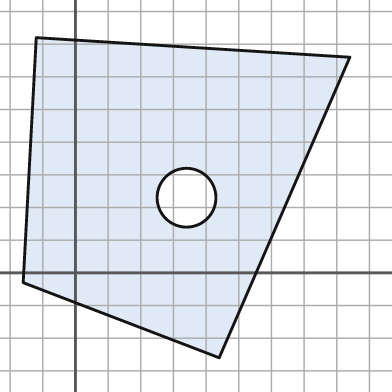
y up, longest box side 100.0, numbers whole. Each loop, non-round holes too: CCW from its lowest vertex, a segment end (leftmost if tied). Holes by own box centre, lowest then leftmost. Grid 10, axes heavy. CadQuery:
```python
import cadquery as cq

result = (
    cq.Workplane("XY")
    .moveTo(44.0, -26.0)
    .lineTo(84.0, 66.0)
    .lineTo(-12.0, 72.0)
    .lineTo(-16.0, -3.0)
    .close()
    .moveTo(34.0, 23.0)
    .circle(9.0)
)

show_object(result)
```